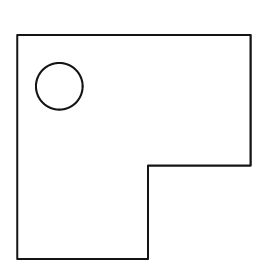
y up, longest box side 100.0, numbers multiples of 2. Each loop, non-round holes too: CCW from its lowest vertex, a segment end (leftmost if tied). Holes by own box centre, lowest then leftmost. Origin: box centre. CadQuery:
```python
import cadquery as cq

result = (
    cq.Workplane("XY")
    .moveTo(-50.0, -48.0)
    .lineTo(6.0, -48.0)
    .lineTo(6.0, -8.0)
    .lineTo(50.0, -8.0)
    .lineTo(50.0, 48.0)
    .lineTo(-50.0, 48.0)
    .close()
    .moveTo(-32.0, 26.0)
    .circle(10.0)
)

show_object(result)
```